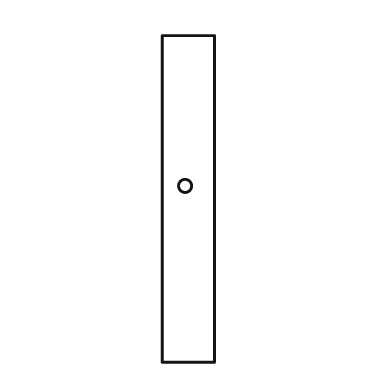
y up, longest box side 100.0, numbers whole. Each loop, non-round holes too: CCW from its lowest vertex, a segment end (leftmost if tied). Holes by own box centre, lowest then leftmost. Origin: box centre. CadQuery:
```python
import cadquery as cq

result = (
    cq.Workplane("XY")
    .moveTo(-8.0, -50.0)
    .lineTo(8.0, -50.0)
    .lineTo(8.0, 50.0)
    .lineTo(-8.0, 50.0)
    .close()
    .moveTo(-1.0, 4.0)
    .circle(2.0)
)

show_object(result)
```